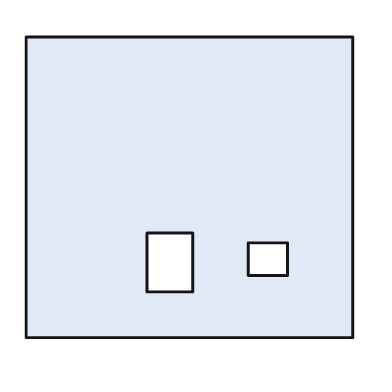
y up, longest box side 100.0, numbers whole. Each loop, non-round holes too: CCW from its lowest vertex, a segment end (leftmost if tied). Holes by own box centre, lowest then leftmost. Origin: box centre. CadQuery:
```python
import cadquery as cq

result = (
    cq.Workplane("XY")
    .moveTo(-50.0, -46.0)
    .lineTo(50.0, -46.0)
    .lineTo(50.0, 46.0)
    .lineTo(-50.0, 46.0)
    .close()
    .moveTo(-13.0, -32.0)
    .lineTo(1.0, -32.0)
    .lineTo(1.0, -14.0)
    .lineTo(-13.0, -14.0)
    .close()
    .moveTo(18.0, -27.0)
    .lineTo(30.0, -27.0)
    .lineTo(30.0, -17.0)
    .lineTo(18.0, -17.0)
    .close()
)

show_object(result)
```